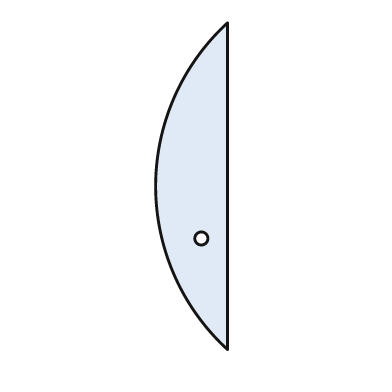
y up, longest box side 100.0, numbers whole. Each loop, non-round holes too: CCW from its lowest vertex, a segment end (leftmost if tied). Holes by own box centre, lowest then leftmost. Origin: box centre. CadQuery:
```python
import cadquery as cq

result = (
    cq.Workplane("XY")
    .moveTo(11.0, -50.0)
    .lineTo(11.0, 50.0)
    .threePointArc((-11.0, 0.0), (11.0, -50.0))
    .close()
    .moveTo(3.0, -16.0)
    .circle(2.0)
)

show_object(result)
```